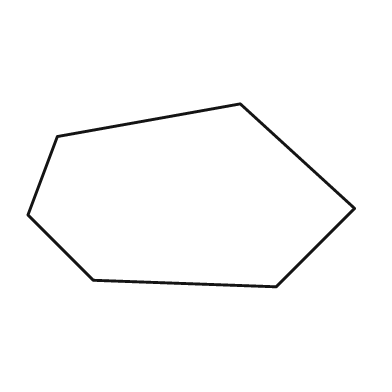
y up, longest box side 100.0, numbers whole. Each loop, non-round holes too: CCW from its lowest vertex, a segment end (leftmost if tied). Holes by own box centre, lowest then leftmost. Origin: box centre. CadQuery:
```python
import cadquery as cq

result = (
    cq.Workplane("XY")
    .moveTo(26.0, -28.0)
    .lineTo(50.0, -4.0)
    .lineTo(15.0, 28.0)
    .lineTo(-41.0, 18.0)
    .lineTo(-50.0, -6.0)
    .lineTo(-30.0, -26.0)
    .close()
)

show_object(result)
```